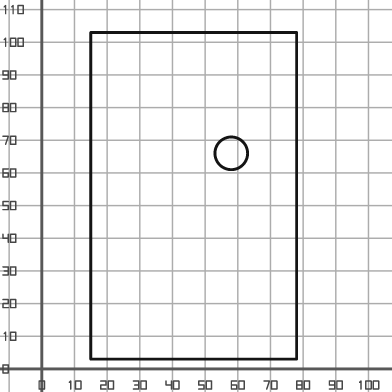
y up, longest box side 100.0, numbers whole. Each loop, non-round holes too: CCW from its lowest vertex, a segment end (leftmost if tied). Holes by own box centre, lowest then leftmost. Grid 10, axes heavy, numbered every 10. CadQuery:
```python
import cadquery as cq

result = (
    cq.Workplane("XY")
    .moveTo(15.0, 3.0)
    .lineTo(78.0, 3.0)
    .lineTo(78.0, 103.0)
    .lineTo(15.0, 103.0)
    .close()
    .moveTo(58.0, 66.0)
    .circle(5.0)
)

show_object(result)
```